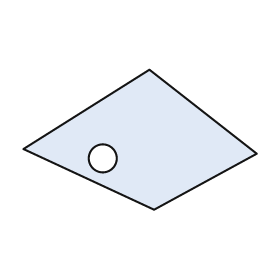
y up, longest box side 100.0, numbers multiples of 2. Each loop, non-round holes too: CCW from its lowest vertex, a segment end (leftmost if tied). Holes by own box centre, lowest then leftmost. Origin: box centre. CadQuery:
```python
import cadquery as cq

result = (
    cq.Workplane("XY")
    .moveTo(6.0, -30.0)
    .lineTo(50.0, -6.0)
    .lineTo(4.0, 30.0)
    .lineTo(-50.0, -4.0)
    .close()
    .moveTo(-16.0, -8.0)
    .circle(6.0)
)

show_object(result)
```